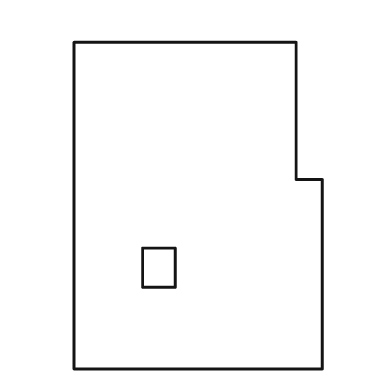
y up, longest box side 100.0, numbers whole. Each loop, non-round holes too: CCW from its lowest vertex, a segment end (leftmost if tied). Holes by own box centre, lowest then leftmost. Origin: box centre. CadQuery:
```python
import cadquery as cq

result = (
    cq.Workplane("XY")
    .moveTo(-38.0, -50.0)
    .lineTo(38.0, -50.0)
    .lineTo(38.0, 8.0)
    .lineTo(30.0, 8.0)
    .lineTo(30.0, 50.0)
    .lineTo(-38.0, 50.0)
    .close()
    .moveTo(-17.0, -25.0)
    .lineTo(-7.0, -25.0)
    .lineTo(-7.0, -13.0)
    .lineTo(-17.0, -13.0)
    .close()
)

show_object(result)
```